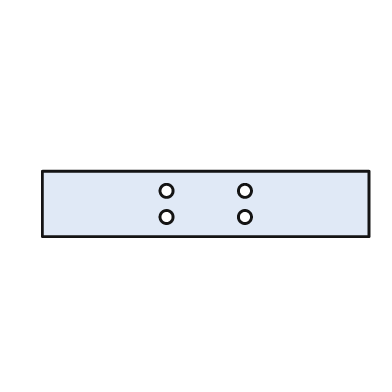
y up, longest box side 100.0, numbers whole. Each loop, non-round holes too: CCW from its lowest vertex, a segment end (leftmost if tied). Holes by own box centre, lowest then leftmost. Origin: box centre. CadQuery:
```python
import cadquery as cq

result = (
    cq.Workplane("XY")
    .moveTo(-50.0, -10.0)
    .lineTo(50.0, -10.0)
    .lineTo(50.0, 10.0)
    .lineTo(-50.0, 10.0)
    .close()
    .moveTo(-12.0, -4.0)
    .circle(2.0)
    .moveTo(12.0, -4.0)
    .circle(2.0)
    .moveTo(-12.0, 4.0)
    .circle(2.0)
    .moveTo(12.0, 4.0)
    .circle(2.0)
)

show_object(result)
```